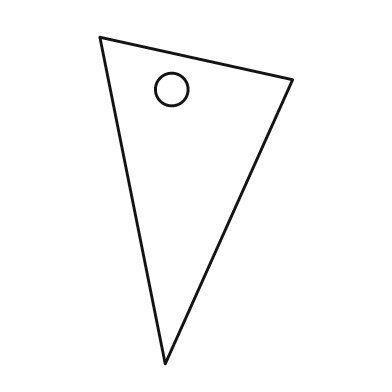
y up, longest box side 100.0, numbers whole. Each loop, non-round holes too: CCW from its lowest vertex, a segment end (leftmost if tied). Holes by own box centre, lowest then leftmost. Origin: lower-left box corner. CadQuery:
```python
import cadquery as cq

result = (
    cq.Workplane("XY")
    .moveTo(20.0, 0.0)
    .lineTo(59.0, 87.0)
    .lineTo(0.0, 100.0)
    .close()
    .moveTo(22.0, 84.0)
    .circle(5.0)
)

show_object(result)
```